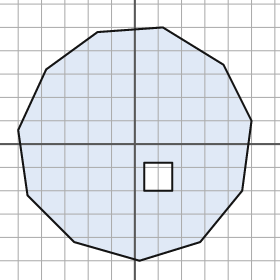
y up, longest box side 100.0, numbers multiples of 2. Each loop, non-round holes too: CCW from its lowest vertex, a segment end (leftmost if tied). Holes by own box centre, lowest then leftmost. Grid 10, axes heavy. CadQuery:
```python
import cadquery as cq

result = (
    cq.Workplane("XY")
    .moveTo(2.0, -50.0)
    .lineTo(28.0, -42.0)
    .lineTo(46.0, -20.0)
    .lineTo(50.0, 10.0)
    .lineTo(38.0, 34.0)
    .lineTo(12.0, 50.0)
    .lineTo(-16.0, 48.0)
    .lineTo(-38.0, 32.0)
    .lineTo(-50.0, 6.0)
    .lineTo(-46.0, -22.0)
    .lineTo(-26.0, -42.0)
    .close()
    .moveTo(4.0, -20.0)
    .lineTo(16.0, -20.0)
    .lineTo(16.0, -8.0)
    .lineTo(4.0, -8.0)
    .close()
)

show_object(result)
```